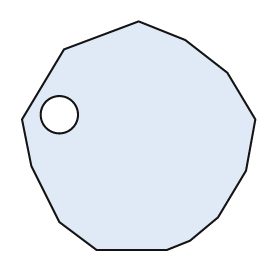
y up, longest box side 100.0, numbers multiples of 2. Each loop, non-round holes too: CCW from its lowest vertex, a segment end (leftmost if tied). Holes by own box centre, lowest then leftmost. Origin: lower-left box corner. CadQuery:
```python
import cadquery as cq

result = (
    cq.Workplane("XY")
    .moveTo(32.0, 0.0)
    .lineTo(62.0, 0.0)
    .lineTo(72.0, 4.0)
    .lineTo(84.0, 14.0)
    .lineTo(96.0, 34.0)
    .lineTo(100.0, 56.0)
    .lineTo(88.0, 76.0)
    .lineTo(70.0, 90.0)
    .lineTo(50.0, 98.0)
    .lineTo(18.0, 86.0)
    .lineTo(0.0, 56.0)
    .lineTo(4.0, 36.0)
    .lineTo(16.0, 12.0)
    .close()
    .moveTo(16.0, 58.0)
    .circle(8.0)
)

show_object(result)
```